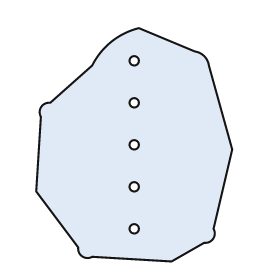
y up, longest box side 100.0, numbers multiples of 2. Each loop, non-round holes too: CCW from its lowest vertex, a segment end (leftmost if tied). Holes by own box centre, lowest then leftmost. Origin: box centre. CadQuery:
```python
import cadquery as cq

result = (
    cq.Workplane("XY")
    .moveTo(16.0, -50.0)
    .lineTo(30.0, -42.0)
    .threePointArc((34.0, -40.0), (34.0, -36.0))
    .lineTo(42.0, -2.0)
    .lineTo(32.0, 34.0)
    .threePointArc((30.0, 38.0), (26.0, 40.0))
    .lineTo(2.0, 50.0)
    .threePointArc((-10.0, 44.0), (-18.0, 34.0))
    .lineTo(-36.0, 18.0)
    .threePointArc((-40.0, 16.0), (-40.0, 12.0))
    .lineTo(-42.0, -20.0)
    .lineTo(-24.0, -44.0)
    .threePointArc((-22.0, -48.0), (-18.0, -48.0))
    .close()
    .moveTo(0.0, -36.0)
    .circle(2.0)
    .moveTo(0.0, -18.0)
    .circle(2.0)
    .moveTo(0.0, 0.0)
    .circle(2.0)
    .moveTo(0.0, 18.0)
    .circle(2.0)
    .moveTo(0.0, 36.0)
    .circle(2.0)
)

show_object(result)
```